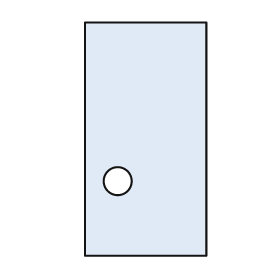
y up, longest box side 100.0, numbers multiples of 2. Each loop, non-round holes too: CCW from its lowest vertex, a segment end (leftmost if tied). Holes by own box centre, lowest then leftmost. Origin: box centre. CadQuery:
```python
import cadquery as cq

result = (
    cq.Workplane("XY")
    .moveTo(-26.0, -50.0)
    .lineTo(26.0, -50.0)
    .lineTo(26.0, 50.0)
    .lineTo(-26.0, 50.0)
    .close()
    .moveTo(-12.0, -18.0)
    .circle(6.0)
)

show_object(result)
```